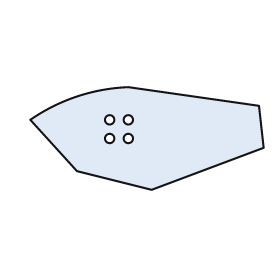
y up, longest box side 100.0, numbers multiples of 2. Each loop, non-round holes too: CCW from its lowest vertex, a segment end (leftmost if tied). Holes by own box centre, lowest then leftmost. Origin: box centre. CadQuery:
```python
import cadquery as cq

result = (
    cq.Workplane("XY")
    .moveTo(2.0, -22.0)
    .lineTo(50.0, -4.0)
    .lineTo(48.0, 14.0)
    .lineTo(-8.0, 22.0)
    .threePointArc((-30.0, 18.0), (-50.0, 8.0))
    .lineTo(-30.0, -14.0)
    .close()
    .moveTo(-16.0, 0.0)
    .circle(2.0)
    .moveTo(-8.0, 0.0)
    .circle(2.0)
    .moveTo(-16.0, 8.0)
    .circle(2.0)
    .moveTo(-8.0, 8.0)
    .circle(2.0)
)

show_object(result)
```